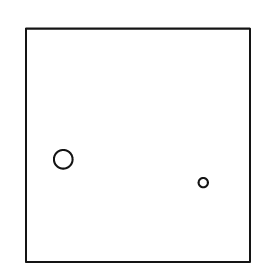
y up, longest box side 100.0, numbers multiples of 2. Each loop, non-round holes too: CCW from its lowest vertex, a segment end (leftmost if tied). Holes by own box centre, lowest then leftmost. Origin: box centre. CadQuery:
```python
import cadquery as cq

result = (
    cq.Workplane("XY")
    .moveTo(-48.0, -50.0)
    .lineTo(48.0, -50.0)
    .lineTo(48.0, 50.0)
    .lineTo(-48.0, 50.0)
    .close()
    .moveTo(28.0, -16.0)
    .circle(2.0)
    .moveTo(-32.0, -6.0)
    .circle(4.0)
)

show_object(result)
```